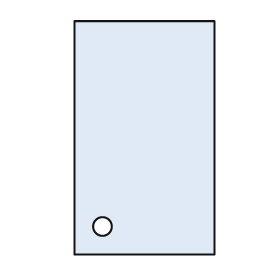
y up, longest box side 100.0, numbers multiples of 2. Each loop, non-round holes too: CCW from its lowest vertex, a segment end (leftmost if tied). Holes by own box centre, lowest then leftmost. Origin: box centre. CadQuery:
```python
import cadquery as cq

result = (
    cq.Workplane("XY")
    .moveTo(-30.0, -50.0)
    .lineTo(30.0, -50.0)
    .lineTo(30.0, 50.0)
    .lineTo(-30.0, 50.0)
    .close()
    .moveTo(-18.0, -38.0)
    .circle(4.0)
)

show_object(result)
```